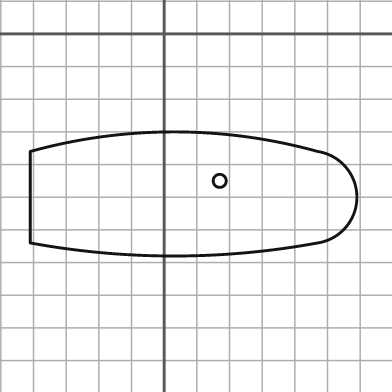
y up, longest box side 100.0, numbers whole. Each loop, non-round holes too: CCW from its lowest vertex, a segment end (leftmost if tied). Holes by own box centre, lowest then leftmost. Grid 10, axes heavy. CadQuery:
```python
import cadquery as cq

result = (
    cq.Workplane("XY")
    .moveTo(-41.0, -64.0)
    .threePointArc((3.0, -68.0), (47.0, -64.0))
    .threePointArc((59.0, -50.0), (47.0, -36.0))
    .threePointArc((3.0, -30.0), (-41.0, -36.0))
    .close()
    .moveTo(17.0, -45.0)
    .circle(2.0)
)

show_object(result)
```